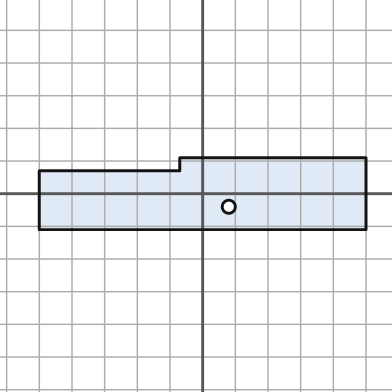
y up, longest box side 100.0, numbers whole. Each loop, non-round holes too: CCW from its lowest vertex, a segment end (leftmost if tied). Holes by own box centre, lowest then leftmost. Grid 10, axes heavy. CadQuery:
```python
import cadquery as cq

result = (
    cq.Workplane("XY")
    .moveTo(-50.0, -11.0)
    .lineTo(50.0, -11.0)
    .lineTo(50.0, 11.0)
    .lineTo(-7.0, 11.0)
    .lineTo(-7.0, 7.0)
    .lineTo(-50.0, 7.0)
    .close()
    .moveTo(8.0, -4.0)
    .circle(2.0)
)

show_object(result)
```